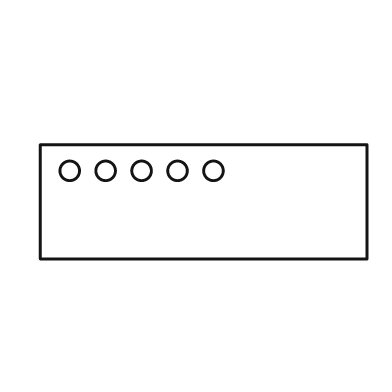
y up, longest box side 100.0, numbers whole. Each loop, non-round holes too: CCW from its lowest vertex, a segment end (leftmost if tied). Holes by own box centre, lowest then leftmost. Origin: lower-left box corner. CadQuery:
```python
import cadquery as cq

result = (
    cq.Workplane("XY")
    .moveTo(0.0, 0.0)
    .lineTo(100.0, 0.0)
    .lineTo(100.0, 35.0)
    .lineTo(0.0, 35.0)
    .close()
    .moveTo(9.0, 27.0)
    .circle(3.0)
    .moveTo(20.0, 27.0)
    .circle(3.0)
    .moveTo(31.0, 27.0)
    .circle(3.0)
    .moveTo(42.0, 27.0)
    .circle(3.0)
    .moveTo(53.0, 27.0)
    .circle(3.0)
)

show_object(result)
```